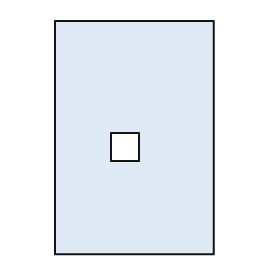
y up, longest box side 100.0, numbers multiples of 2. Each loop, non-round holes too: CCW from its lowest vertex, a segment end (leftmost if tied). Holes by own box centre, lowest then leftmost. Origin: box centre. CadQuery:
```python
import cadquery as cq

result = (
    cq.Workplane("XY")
    .moveTo(-34.0, -50.0)
    .lineTo(34.0, -50.0)
    .lineTo(34.0, 50.0)
    .lineTo(-34.0, 50.0)
    .close()
    .moveTo(-10.0, -10.0)
    .lineTo(2.0, -10.0)
    .lineTo(2.0, 2.0)
    .lineTo(-10.0, 2.0)
    .close()
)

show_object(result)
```